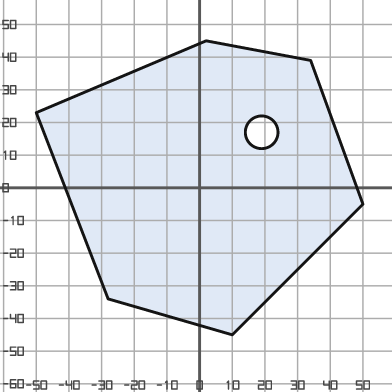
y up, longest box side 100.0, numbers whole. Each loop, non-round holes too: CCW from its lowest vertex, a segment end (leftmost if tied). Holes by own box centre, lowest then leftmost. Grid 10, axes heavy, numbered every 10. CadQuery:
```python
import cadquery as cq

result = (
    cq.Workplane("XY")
    .moveTo(10.0, -45.0)
    .lineTo(50.0, -5.0)
    .lineTo(34.0, 39.0)
    .lineTo(2.0, 45.0)
    .lineTo(-50.0, 23.0)
    .lineTo(-28.0, -34.0)
    .close()
    .moveTo(19.0, 17.0)
    .circle(5.0)
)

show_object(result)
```